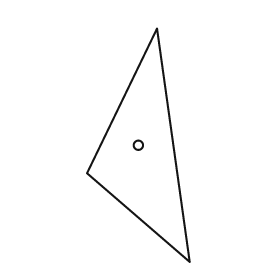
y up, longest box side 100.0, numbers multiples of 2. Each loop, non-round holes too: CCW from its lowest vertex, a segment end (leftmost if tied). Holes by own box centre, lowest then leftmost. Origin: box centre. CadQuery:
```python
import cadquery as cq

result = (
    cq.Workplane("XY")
    .moveTo(22.0, -50.0)
    .lineTo(8.0, 50.0)
    .lineTo(-22.0, -12.0)
    .close()
    .moveTo(0.0, 0.0)
    .circle(2.0)
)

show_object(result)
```